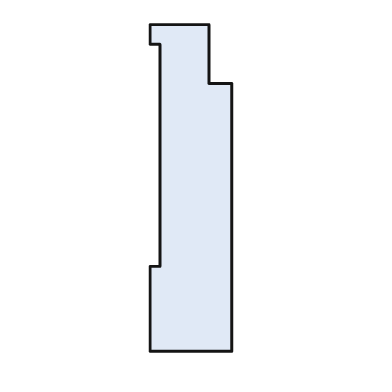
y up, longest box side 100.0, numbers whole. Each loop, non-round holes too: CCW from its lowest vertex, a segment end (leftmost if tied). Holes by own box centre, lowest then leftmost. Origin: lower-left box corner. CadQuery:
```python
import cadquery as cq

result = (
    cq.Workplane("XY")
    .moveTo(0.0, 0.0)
    .lineTo(25.0, 0.0)
    .lineTo(25.0, 82.0)
    .lineTo(18.0, 82.0)
    .lineTo(18.0, 100.0)
    .lineTo(0.0, 100.0)
    .lineTo(0.0, 94.0)
    .lineTo(3.0, 94.0)
    .lineTo(3.0, 26.0)
    .lineTo(0.0, 26.0)
    .close()
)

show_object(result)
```